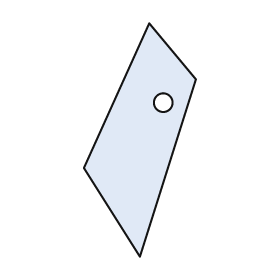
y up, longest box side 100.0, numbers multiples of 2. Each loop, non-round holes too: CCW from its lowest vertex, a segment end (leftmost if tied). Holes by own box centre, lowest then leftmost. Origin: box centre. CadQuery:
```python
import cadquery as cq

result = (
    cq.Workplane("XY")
    .moveTo(0.0, -50.0)
    .lineTo(24.0, 26.0)
    .lineTo(4.0, 50.0)
    .lineTo(-24.0, -12.0)
    .close()
    .moveTo(10.0, 16.0)
    .circle(4.0)
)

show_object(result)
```